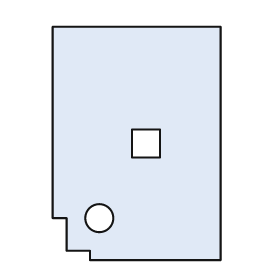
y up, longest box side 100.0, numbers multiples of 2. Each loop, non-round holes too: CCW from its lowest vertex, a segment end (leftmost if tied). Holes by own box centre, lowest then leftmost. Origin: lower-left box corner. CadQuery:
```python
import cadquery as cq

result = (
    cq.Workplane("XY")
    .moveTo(16.0, 0.0)
    .lineTo(72.0, 0.0)
    .lineTo(72.0, 100.0)
    .lineTo(0.0, 100.0)
    .lineTo(0.0, 18.0)
    .lineTo(6.0, 18.0)
    .lineTo(6.0, 4.0)
    .lineTo(16.0, 4.0)
    .close()
    .moveTo(20.0, 18.0)
    .circle(6.0)
    .moveTo(34.0, 44.0)
    .lineTo(46.0, 44.0)
    .lineTo(46.0, 56.0)
    .lineTo(34.0, 56.0)
    .close()
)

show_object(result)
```